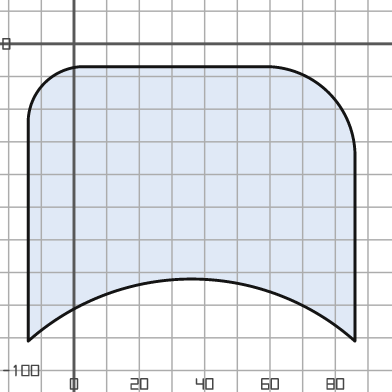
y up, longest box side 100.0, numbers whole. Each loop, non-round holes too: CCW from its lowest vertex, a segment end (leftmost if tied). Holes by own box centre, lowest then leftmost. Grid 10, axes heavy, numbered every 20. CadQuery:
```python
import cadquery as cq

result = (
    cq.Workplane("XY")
    .moveTo(-14.0, -91.0)
    .threePointArc((36.0, -72.0), (86.0, -91.0))
    .lineTo(86.0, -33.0)
    .threePointArc((78.0, -15.0), (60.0, -7.0))
    .lineTo(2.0, -7.0)
    .threePointArc((-9.0, -12.0), (-14.0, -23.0))
    .close()
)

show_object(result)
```